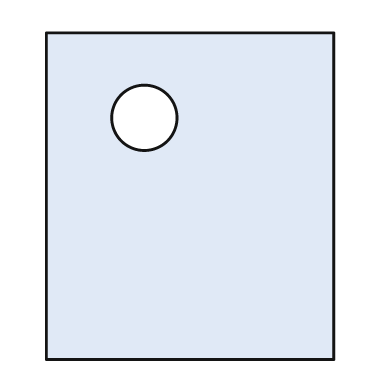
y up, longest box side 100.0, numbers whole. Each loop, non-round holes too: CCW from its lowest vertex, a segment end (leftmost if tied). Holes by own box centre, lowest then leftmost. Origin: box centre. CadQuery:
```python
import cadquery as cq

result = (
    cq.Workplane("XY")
    .moveTo(-44.0, -50.0)
    .lineTo(44.0, -50.0)
    .lineTo(44.0, 50.0)
    .lineTo(-44.0, 50.0)
    .close()
    .moveTo(-14.0, 24.0)
    .circle(10.0)
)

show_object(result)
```